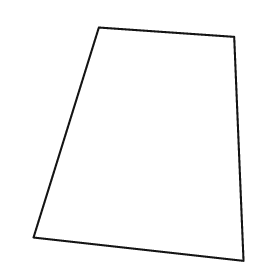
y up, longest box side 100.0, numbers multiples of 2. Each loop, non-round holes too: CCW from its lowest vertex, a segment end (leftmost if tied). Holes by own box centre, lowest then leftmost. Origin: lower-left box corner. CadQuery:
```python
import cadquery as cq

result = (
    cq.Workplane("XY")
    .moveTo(90.0, 0.0)
    .lineTo(86.0, 96.0)
    .lineTo(28.0, 100.0)
    .lineTo(0.0, 10.0)
    .close()
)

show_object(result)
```